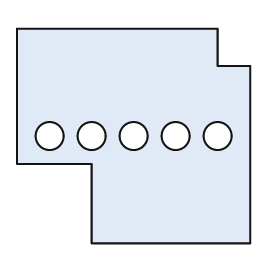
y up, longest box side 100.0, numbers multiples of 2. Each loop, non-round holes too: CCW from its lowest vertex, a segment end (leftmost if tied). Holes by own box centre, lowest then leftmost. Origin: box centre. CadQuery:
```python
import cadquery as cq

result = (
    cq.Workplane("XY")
    .moveTo(-18.0, -46.0)
    .lineTo(50.0, -46.0)
    .lineTo(50.0, 30.0)
    .lineTo(36.0, 30.0)
    .lineTo(36.0, 46.0)
    .lineTo(-50.0, 46.0)
    .lineTo(-50.0, -12.0)
    .lineTo(-18.0, -12.0)
    .close()
    .moveTo(-36.0, 0.0)
    .circle(6.0)
    .moveTo(-18.0, 0.0)
    .circle(6.0)
    .moveTo(0.0, 0.0)
    .circle(6.0)
    .moveTo(18.0, 0.0)
    .circle(6.0)
    .moveTo(36.0, 0.0)
    .circle(6.0)
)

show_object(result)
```